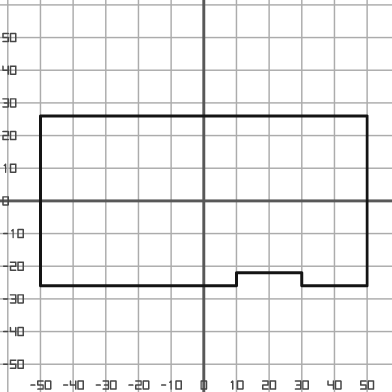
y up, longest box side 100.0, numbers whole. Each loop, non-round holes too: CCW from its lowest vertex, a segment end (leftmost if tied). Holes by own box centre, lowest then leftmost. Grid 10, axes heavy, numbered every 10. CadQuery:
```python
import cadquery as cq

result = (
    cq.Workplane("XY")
    .moveTo(-50.0, -26.0)
    .lineTo(10.0, -26.0)
    .lineTo(10.0, -22.0)
    .lineTo(30.0, -22.0)
    .lineTo(30.0, -26.0)
    .lineTo(50.0, -26.0)
    .lineTo(50.0, 26.0)
    .lineTo(-50.0, 26.0)
    .close()
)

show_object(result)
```